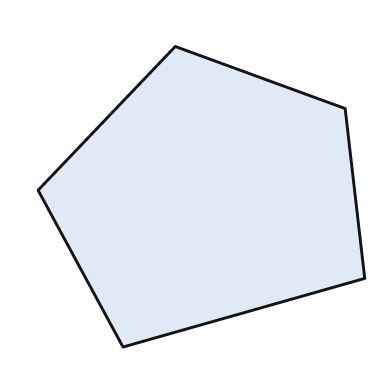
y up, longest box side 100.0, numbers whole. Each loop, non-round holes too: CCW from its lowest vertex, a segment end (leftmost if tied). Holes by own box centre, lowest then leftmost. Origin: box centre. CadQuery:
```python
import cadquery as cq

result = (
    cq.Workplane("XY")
    .moveTo(-24.0, -46.0)
    .lineTo(50.0, -25.0)
    .lineTo(44.0, 27.0)
    .lineTo(-8.0, 46.0)
    .lineTo(-50.0, 2.0)
    .close()
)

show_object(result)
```